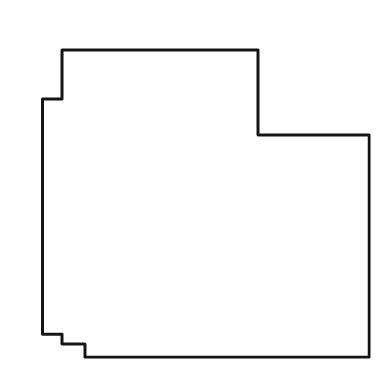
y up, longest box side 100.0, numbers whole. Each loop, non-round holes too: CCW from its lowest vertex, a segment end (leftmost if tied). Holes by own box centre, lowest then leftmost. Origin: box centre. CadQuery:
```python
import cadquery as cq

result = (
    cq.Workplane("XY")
    .moveTo(-37.0, -47.0)
    .lineTo(50.0, -47.0)
    .lineTo(50.0, 21.0)
    .lineTo(16.0, 21.0)
    .lineTo(16.0, 47.0)
    .lineTo(-44.0, 47.0)
    .lineTo(-44.0, 32.0)
    .lineTo(-50.0, 32.0)
    .lineTo(-50.0, -40.0)
    .lineTo(-44.0, -40.0)
    .lineTo(-44.0, -43.0)
    .lineTo(-37.0, -43.0)
    .close()
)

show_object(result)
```